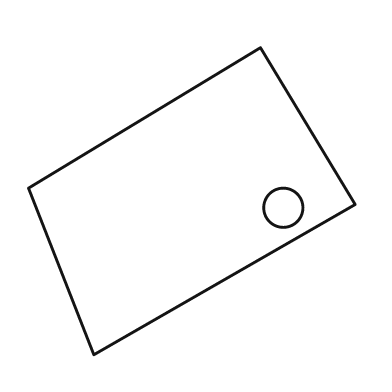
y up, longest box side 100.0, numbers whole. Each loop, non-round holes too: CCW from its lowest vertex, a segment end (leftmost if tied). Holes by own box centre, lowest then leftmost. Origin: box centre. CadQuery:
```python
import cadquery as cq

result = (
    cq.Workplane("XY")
    .moveTo(-30.0, -47.0)
    .lineTo(50.0, -1.0)
    .lineTo(21.0, 47.0)
    .lineTo(-50.0, 4.0)
    .close()
    .moveTo(28.0, -2.0)
    .circle(6.0)
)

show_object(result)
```